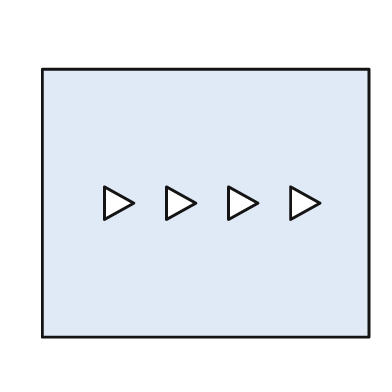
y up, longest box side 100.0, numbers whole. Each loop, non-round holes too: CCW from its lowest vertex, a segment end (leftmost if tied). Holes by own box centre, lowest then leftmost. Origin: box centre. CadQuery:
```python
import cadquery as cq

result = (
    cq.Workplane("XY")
    .moveTo(-50.0, -41.0)
    .lineTo(50.0, -41.0)
    .lineTo(50.0, 41.0)
    .lineTo(-50.0, 41.0)
    .close()
    .moveTo(-31.0, -5.0)
    .lineTo(-22.0, 0.0)
    .lineTo(-31.0, 5.0)
    .close()
    .moveTo(-12.0, -5.0)
    .lineTo(-3.0, 0.0)
    .lineTo(-12.0, 5.0)
    .close()
    .moveTo(7.0, -5.0)
    .lineTo(16.0, 0.0)
    .lineTo(7.0, 5.0)
    .close()
    .moveTo(26.0, -5.0)
    .lineTo(35.0, 0.0)
    .lineTo(26.0, 5.0)
    .close()
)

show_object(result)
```